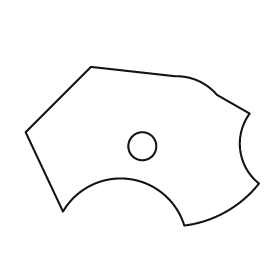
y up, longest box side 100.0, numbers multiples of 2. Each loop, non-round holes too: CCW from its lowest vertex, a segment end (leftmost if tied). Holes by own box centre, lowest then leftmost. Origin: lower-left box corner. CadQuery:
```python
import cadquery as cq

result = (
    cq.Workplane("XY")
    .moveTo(68.0, 0.0)
    .threePointArc((86.0, 6.0), (100.0, 18.0))
    .threePointArc((92.0, 32.0), (96.0, 48.0))
    .lineTo(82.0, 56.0)
    .threePointArc((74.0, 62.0), (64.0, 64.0))
    .lineTo(28.0, 68.0)
    .lineTo(0.0, 40.0)
    .lineTo(16.0, 6.0)
    .threePointArc((44.0, 20.0), (68.0, 0.0))
    .close()
    .moveTo(50.0, 34.0)
    .circle(6.0)
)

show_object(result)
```